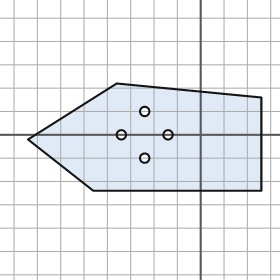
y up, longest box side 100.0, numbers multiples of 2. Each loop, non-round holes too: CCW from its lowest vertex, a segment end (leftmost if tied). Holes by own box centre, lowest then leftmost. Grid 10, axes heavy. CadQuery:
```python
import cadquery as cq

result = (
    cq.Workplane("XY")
    .moveTo(-46.0, -24.0)
    .lineTo(26.0, -24.0)
    .lineTo(26.0, 16.0)
    .lineTo(-36.0, 22.0)
    .lineTo(-74.0, -2.0)
    .close()
    .moveTo(-24.0, -10.0)
    .circle(2.0)
    .moveTo(-34.0, 0.0)
    .circle(2.0)
    .moveTo(-14.0, 0.0)
    .circle(2.0)
    .moveTo(-24.0, 10.0)
    .circle(2.0)
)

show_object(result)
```